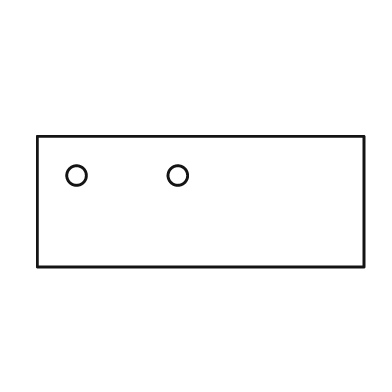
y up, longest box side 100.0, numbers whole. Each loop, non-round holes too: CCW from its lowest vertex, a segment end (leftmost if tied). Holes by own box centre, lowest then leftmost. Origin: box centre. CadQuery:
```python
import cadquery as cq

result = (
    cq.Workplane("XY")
    .moveTo(-50.0, -20.0)
    .lineTo(50.0, -20.0)
    .lineTo(50.0, 20.0)
    .lineTo(-50.0, 20.0)
    .close()
    .moveTo(-38.0, 8.0)
    .circle(3.0)
    .moveTo(-7.0, 8.0)
    .circle(3.0)
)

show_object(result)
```